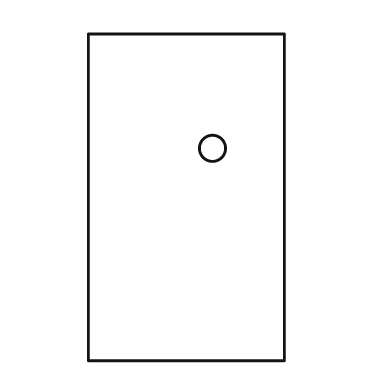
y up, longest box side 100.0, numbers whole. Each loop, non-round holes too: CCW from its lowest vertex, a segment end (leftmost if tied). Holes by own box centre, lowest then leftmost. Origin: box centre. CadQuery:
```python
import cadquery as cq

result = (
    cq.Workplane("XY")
    .moveTo(-30.0, -50.0)
    .lineTo(30.0, -50.0)
    .lineTo(30.0, 50.0)
    .lineTo(-30.0, 50.0)
    .close()
    .moveTo(8.0, 15.0)
    .circle(4.0)
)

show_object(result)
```